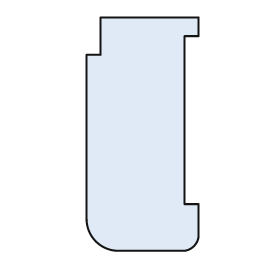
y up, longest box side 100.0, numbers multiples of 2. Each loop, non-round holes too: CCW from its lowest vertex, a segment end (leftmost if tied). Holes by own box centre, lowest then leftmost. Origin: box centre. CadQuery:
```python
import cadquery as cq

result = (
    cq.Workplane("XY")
    .moveTo(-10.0, -50.0)
    .lineTo(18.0, -50.0)
    .threePointArc((22.0, -48.0), (24.0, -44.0))
    .lineTo(24.0, -30.0)
    .lineTo(18.0, -30.0)
    .lineTo(18.0, 42.0)
    .lineTo(24.0, 42.0)
    .lineTo(24.0, 50.0)
    .lineTo(-18.0, 50.0)
    .lineTo(-18.0, 34.0)
    .lineTo(-24.0, 34.0)
    .lineTo(-24.0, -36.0)
    .threePointArc((-20.0, -46.0), (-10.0, -50.0))
    .close()
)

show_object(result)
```